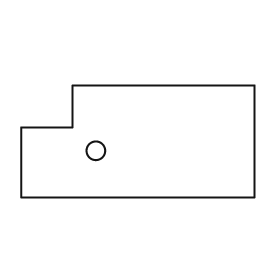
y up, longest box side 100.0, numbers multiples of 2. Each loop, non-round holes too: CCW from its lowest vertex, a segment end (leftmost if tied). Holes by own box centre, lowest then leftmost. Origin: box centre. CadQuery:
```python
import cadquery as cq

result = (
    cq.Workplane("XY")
    .moveTo(-50.0, -24.0)
    .lineTo(50.0, -24.0)
    .lineTo(50.0, 24.0)
    .lineTo(-28.0, 24.0)
    .lineTo(-28.0, 6.0)
    .lineTo(-50.0, 6.0)
    .close()
    .moveTo(-18.0, -4.0)
    .circle(4.0)
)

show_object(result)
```